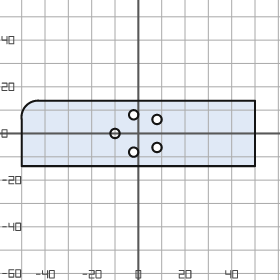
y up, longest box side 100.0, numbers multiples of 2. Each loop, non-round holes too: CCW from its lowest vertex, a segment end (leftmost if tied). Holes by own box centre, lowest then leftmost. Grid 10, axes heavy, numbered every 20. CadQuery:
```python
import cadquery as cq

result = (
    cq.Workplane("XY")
    .moveTo(-50.0, -14.0)
    .lineTo(50.0, -14.0)
    .lineTo(50.0, 14.0)
    .lineTo(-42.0, 14.0)
    .threePointArc((-48.0, 12.0), (-50.0, 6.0))
    .close()
    .moveTo(-2.0, -8.0)
    .circle(2.0)
    .moveTo(8.0, -6.0)
    .circle(2.0)
    .moveTo(-10.0, 0.0)
    .circle(2.0)
    .moveTo(8.0, 6.0)
    .circle(2.0)
    .moveTo(-2.0, 8.0)
    .circle(2.0)
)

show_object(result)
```